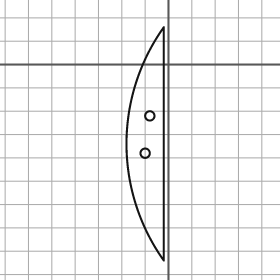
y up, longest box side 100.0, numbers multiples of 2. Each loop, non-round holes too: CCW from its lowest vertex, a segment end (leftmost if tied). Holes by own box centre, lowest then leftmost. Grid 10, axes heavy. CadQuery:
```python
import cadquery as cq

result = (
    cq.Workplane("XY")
    .moveTo(-2.0, -84.0)
    .lineTo(-2.0, 16.0)
    .threePointArc((-18.0, -34.0), (-2.0, -84.0))
    .close()
    .moveTo(-10.0, -38.0)
    .circle(2.0)
    .moveTo(-8.0, -22.0)
    .circle(2.0)
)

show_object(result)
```